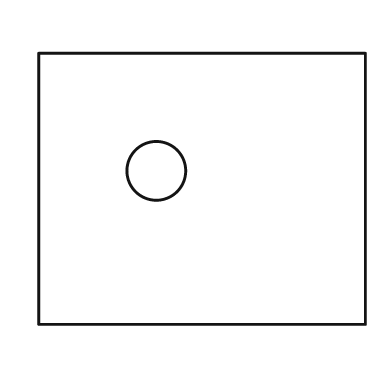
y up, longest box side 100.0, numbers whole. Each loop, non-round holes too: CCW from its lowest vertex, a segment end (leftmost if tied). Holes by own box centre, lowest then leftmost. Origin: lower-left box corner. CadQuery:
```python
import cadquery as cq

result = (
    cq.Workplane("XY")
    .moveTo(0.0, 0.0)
    .lineTo(100.0, 0.0)
    .lineTo(100.0, 83.0)
    .lineTo(0.0, 83.0)
    .close()
    .moveTo(36.0, 47.0)
    .circle(9.0)
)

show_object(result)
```